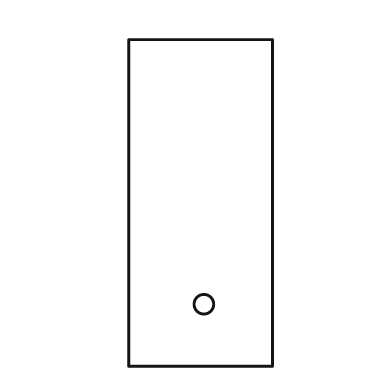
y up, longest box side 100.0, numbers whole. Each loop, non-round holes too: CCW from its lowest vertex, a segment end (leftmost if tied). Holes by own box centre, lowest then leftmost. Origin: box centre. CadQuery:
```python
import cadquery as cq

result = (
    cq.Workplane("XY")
    .moveTo(-22.0, -50.0)
    .lineTo(22.0, -50.0)
    .lineTo(22.0, 50.0)
    .lineTo(-22.0, 50.0)
    .close()
    .moveTo(1.0, -31.0)
    .circle(3.0)
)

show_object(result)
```